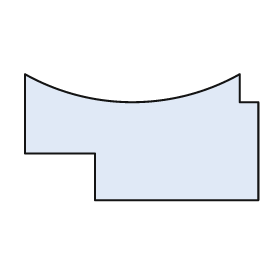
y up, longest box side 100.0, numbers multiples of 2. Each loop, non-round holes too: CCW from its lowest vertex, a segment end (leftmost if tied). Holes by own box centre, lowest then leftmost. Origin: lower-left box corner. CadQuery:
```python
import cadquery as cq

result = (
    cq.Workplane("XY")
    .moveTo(30.0, 0.0)
    .lineTo(100.0, 0.0)
    .lineTo(100.0, 42.0)
    .lineTo(92.0, 42.0)
    .lineTo(92.0, 54.0)
    .threePointArc((46.0, 42.0), (0.0, 54.0))
    .lineTo(0.0, 20.0)
    .lineTo(30.0, 20.0)
    .close()
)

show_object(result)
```